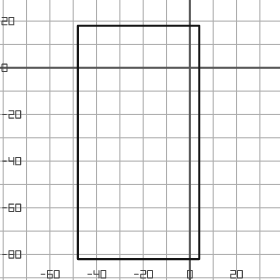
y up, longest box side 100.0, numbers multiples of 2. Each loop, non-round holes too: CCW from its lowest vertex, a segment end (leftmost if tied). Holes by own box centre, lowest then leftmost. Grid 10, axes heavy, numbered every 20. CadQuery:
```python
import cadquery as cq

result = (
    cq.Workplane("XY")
    .moveTo(-48.0, -82.0)
    .lineTo(4.0, -82.0)
    .lineTo(4.0, 18.0)
    .lineTo(-48.0, 18.0)
    .close()
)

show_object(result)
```